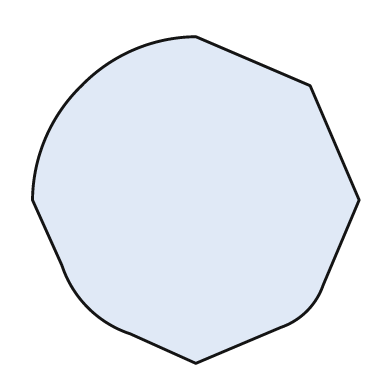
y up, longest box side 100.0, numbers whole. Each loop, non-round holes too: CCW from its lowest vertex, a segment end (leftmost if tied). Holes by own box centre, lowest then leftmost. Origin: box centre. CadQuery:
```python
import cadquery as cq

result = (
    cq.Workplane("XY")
    .moveTo(0.0, -50.0)
    .lineTo(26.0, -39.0)
    .threePointArc((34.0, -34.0), (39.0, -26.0))
    .lineTo(50.0, 0.0)
    .lineTo(35.0, 35.0)
    .lineTo(0.0, 50.0)
    .threePointArc((-19.0, 46.0), (-35.0, 35.0))
    .threePointArc((-46.0, 19.0), (-50.0, 0.0))
    .lineTo(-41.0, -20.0)
    .threePointArc((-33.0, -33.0), (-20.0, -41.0))
    .close()
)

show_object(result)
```